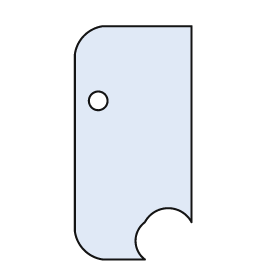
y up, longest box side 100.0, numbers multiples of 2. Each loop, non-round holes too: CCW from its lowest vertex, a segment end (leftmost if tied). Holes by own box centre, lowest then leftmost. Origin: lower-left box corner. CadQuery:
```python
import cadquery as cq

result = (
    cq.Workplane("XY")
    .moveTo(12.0, 0.0)
    .lineTo(30.0, 0.0)
    .threePointArc((26.0, 8.0), (30.0, 16.0))
    .threePointArc((40.0, 22.0), (50.0, 16.0))
    .lineTo(50.0, 100.0)
    .lineTo(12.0, 100.0)
    .threePointArc((4.0, 96.0), (0.0, 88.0))
    .lineTo(0.0, 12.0)
    .threePointArc((4.0, 4.0), (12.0, 0.0))
    .close()
    .moveTo(10.0, 68.0)
    .circle(4.0)
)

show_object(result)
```